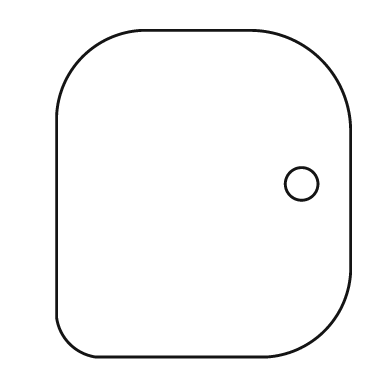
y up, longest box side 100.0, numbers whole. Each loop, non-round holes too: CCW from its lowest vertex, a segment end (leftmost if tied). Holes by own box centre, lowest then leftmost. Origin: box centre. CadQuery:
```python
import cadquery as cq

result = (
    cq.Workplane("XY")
    .moveTo(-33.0, -50.0)
    .lineTo(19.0, -50.0)
    .threePointArc((37.0, -42.0), (45.0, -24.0))
    .lineTo(45.0, 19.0)
    .threePointArc((36.0, 41.0), (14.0, 50.0))
    .lineTo(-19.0, 50.0)
    .threePointArc((-37.0, 42.0), (-45.0, 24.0))
    .lineTo(-45.0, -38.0)
    .threePointArc((-41.0, -46.0), (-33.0, -50.0))
    .close()
    .moveTo(30.0, 3.0)
    .circle(5.0)
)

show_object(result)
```